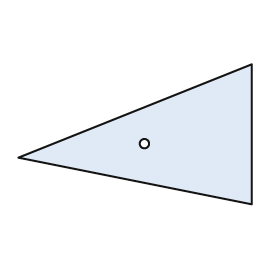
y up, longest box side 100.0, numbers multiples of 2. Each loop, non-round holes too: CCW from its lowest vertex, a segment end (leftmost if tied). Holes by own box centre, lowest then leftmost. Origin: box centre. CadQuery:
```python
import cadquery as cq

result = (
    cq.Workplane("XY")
    .moveTo(50.0, -30.0)
    .lineTo(50.0, 30.0)
    .lineTo(-50.0, -10.0)
    .close()
    .moveTo(4.0, -4.0)
    .circle(2.0)
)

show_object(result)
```